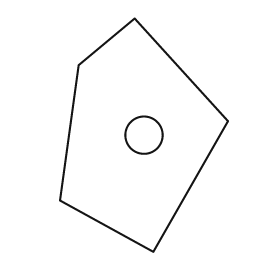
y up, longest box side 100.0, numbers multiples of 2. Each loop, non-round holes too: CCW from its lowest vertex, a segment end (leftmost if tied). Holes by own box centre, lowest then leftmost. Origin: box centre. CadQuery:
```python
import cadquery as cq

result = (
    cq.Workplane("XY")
    .moveTo(4.0, -50.0)
    .lineTo(36.0, 6.0)
    .lineTo(-4.0, 50.0)
    .lineTo(-28.0, 30.0)
    .lineTo(-36.0, -28.0)
    .close()
    .moveTo(0.0, 0.0)
    .circle(8.0)
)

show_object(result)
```